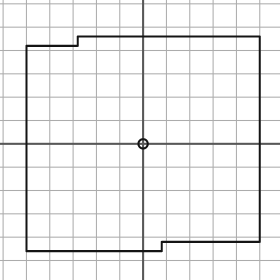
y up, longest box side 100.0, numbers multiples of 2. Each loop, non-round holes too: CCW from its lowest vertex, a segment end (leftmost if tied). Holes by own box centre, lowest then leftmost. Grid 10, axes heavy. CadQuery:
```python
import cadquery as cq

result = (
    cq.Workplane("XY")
    .moveTo(-50.0, -46.0)
    .lineTo(8.0, -46.0)
    .lineTo(8.0, -42.0)
    .lineTo(50.0, -42.0)
    .lineTo(50.0, 46.0)
    .lineTo(-28.0, 46.0)
    .lineTo(-28.0, 42.0)
    .lineTo(-50.0, 42.0)
    .close()
    .moveTo(0.0, 0.0)
    .circle(2.0)
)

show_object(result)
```